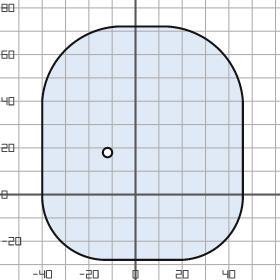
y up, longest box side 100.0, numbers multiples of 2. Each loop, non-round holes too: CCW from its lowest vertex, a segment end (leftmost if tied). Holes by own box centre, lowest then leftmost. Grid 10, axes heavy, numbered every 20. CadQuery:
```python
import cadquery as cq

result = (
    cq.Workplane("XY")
    .moveTo(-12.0, -28.0)
    .lineTo(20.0, -28.0)
    .threePointArc((38.0, -20.0), (46.0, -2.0))
    .lineTo(46.0, 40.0)
    .threePointArc((36.0, 62.0), (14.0, 72.0))
    .lineTo(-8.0, 72.0)
    .threePointArc((-30.0, 62.0), (-40.0, 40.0))
    .lineTo(-40.0, 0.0)
    .threePointArc((-32.0, -20.0), (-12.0, -28.0))
    .close()
    .moveTo(-12.0, 18.0)
    .circle(2.0)
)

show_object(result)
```